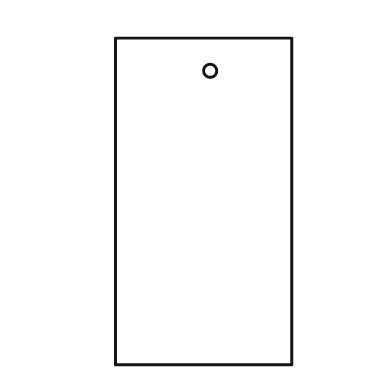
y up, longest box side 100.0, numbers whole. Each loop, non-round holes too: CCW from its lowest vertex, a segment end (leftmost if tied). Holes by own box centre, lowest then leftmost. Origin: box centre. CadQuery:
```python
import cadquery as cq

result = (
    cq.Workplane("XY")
    .moveTo(-27.0, -50.0)
    .lineTo(27.0, -50.0)
    .lineTo(27.0, 50.0)
    .lineTo(-27.0, 50.0)
    .close()
    .moveTo(2.0, 40.0)
    .circle(2.0)
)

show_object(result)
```